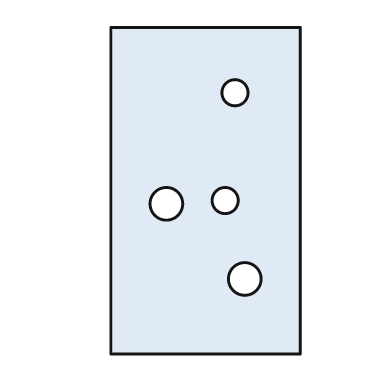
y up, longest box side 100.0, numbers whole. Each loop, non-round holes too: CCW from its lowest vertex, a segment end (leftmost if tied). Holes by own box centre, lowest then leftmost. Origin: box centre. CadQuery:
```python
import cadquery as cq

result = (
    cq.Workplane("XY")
    .moveTo(-29.0, -50.0)
    .lineTo(29.0, -50.0)
    .lineTo(29.0, 50.0)
    .lineTo(-29.0, 50.0)
    .close()
    .moveTo(12.0, -27.0)
    .circle(5.0)
    .moveTo(-12.0, -4.0)
    .circle(5.0)
    .moveTo(6.0, -3.0)
    .circle(4.0)
    .moveTo(9.0, 30.0)
    .circle(4.0)
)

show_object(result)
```